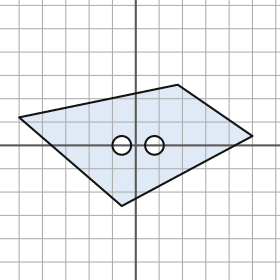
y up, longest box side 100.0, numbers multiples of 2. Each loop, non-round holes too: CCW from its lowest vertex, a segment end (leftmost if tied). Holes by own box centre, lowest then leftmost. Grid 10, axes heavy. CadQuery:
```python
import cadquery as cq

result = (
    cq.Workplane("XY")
    .moveTo(-6.0, -26.0)
    .lineTo(50.0, 4.0)
    .lineTo(18.0, 26.0)
    .lineTo(-50.0, 12.0)
    .close()
    .moveTo(-6.0, 0.0)
    .circle(4.0)
    .moveTo(8.0, 0.0)
    .circle(4.0)
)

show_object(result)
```